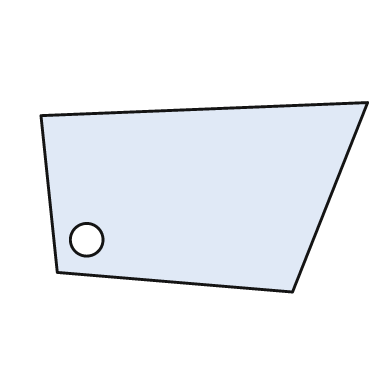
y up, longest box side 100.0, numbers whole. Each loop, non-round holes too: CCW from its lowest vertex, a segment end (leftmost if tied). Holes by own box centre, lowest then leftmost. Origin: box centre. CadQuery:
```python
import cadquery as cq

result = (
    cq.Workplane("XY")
    .moveTo(27.0, -29.0)
    .lineTo(50.0, 29.0)
    .lineTo(-50.0, 25.0)
    .lineTo(-45.0, -23.0)
    .close()
    .moveTo(-36.0, -13.0)
    .circle(5.0)
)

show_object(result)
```